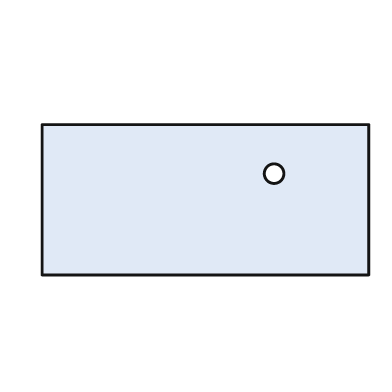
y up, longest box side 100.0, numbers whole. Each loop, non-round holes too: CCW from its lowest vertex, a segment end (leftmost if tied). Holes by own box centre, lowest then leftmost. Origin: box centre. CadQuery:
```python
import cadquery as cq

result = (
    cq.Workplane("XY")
    .moveTo(-50.0, -23.0)
    .lineTo(50.0, -23.0)
    .lineTo(50.0, 23.0)
    .lineTo(-50.0, 23.0)
    .close()
    .moveTo(21.0, 8.0)
    .circle(3.0)
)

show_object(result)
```